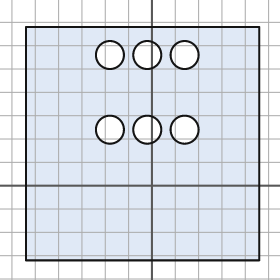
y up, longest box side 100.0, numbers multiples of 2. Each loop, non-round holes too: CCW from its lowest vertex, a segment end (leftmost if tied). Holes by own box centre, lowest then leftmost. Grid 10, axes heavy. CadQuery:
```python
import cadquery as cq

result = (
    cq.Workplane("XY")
    .moveTo(-54.0, -32.0)
    .lineTo(46.0, -32.0)
    .lineTo(46.0, 68.0)
    .lineTo(-54.0, 68.0)
    .close()
    .moveTo(-18.0, 24.0)
    .circle(6.0)
    .moveTo(-2.0, 24.0)
    .circle(6.0)
    .moveTo(14.0, 24.0)
    .circle(6.0)
    .moveTo(-18.0, 56.0)
    .circle(6.0)
    .moveTo(-2.0, 56.0)
    .circle(6.0)
    .moveTo(14.0, 56.0)
    .circle(6.0)
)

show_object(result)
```